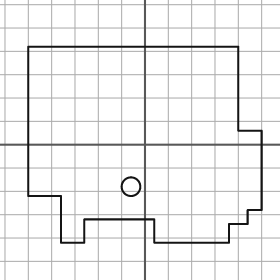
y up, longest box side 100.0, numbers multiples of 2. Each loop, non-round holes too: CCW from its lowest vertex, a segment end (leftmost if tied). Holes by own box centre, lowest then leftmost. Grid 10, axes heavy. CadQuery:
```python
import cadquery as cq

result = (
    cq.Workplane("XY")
    .moveTo(-36.0, -42.0)
    .lineTo(-26.0, -42.0)
    .lineTo(-26.0, -32.0)
    .lineTo(4.0, -32.0)
    .lineTo(4.0, -42.0)
    .lineTo(36.0, -42.0)
    .lineTo(36.0, -34.0)
    .lineTo(44.0, -34.0)
    .lineTo(44.0, -28.0)
    .lineTo(50.0, -28.0)
    .lineTo(50.0, 6.0)
    .lineTo(40.0, 6.0)
    .lineTo(40.0, 42.0)
    .lineTo(-50.0, 42.0)
    .lineTo(-50.0, -22.0)
    .lineTo(-36.0, -22.0)
    .close()
    .moveTo(-6.0, -18.0)
    .circle(4.0)
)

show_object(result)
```